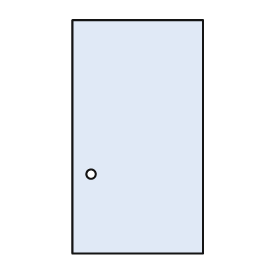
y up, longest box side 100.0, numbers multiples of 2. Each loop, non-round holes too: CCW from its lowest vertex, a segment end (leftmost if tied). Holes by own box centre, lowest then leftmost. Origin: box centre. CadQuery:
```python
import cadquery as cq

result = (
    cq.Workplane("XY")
    .moveTo(-28.0, -50.0)
    .lineTo(28.0, -50.0)
    .lineTo(28.0, 50.0)
    .lineTo(-28.0, 50.0)
    .close()
    .moveTo(-20.0, -16.0)
    .circle(2.0)
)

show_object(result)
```